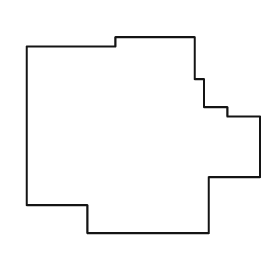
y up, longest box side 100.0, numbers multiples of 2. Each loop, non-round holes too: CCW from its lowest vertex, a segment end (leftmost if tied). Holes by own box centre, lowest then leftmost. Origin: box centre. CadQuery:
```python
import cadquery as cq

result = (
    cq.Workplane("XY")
    .moveTo(-24.0, -42.0)
    .lineTo(28.0, -42.0)
    .lineTo(28.0, -18.0)
    .lineTo(50.0, -18.0)
    .lineTo(50.0, 8.0)
    .lineTo(36.0, 8.0)
    .lineTo(36.0, 12.0)
    .lineTo(26.0, 12.0)
    .lineTo(26.0, 24.0)
    .lineTo(22.0, 24.0)
    .lineTo(22.0, 42.0)
    .lineTo(-12.0, 42.0)
    .lineTo(-12.0, 38.0)
    .lineTo(-50.0, 38.0)
    .lineTo(-50.0, -30.0)
    .lineTo(-24.0, -30.0)
    .close()
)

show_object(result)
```